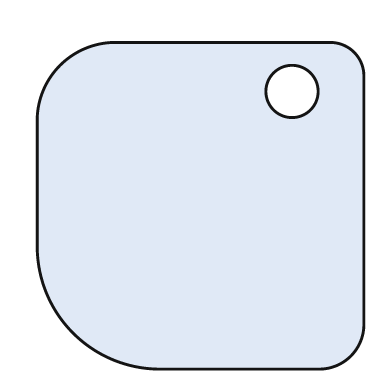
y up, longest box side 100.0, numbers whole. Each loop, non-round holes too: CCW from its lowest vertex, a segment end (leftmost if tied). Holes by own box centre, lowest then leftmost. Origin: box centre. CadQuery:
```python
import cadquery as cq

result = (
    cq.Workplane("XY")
    .moveTo(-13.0, -50.0)
    .lineTo(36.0, -50.0)
    .threePointArc((46.0, -46.0), (50.0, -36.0))
    .lineTo(50.0, 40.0)
    .threePointArc((47.0, 47.0), (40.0, 50.0))
    .lineTo(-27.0, 50.0)
    .threePointArc((-43.0, 43.0), (-50.0, 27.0))
    .lineTo(-50.0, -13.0)
    .threePointArc((-39.0, -39.0), (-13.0, -50.0))
    .close()
    .moveTo(28.0, 35.0)
    .circle(8.0)
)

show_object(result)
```